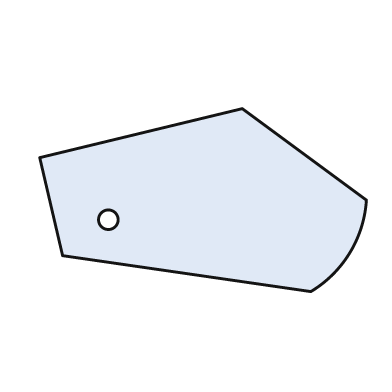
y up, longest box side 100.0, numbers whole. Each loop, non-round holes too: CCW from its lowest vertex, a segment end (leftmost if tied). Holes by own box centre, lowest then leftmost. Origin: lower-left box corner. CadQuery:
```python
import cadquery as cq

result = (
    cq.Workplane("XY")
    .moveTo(83.0, 0.0)
    .threePointArc((95.0, 12.0), (100.0, 28.0))
    .lineTo(62.0, 56.0)
    .lineTo(0.0, 41.0)
    .lineTo(7.0, 11.0)
    .close()
    .moveTo(21.0, 22.0)
    .circle(3.0)
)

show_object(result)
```